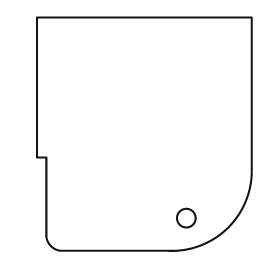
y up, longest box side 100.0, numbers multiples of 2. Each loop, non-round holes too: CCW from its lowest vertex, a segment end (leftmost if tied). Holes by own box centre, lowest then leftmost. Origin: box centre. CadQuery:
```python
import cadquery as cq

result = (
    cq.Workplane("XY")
    .moveTo(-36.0, -50.0)
    .lineTo(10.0, -50.0)
    .threePointArc((36.0, -40.0), (46.0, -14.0))
    .lineTo(46.0, 50.0)
    .lineTo(-46.0, 50.0)
    .lineTo(-46.0, -10.0)
    .lineTo(-42.0, -10.0)
    .lineTo(-42.0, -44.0)
    .threePointArc((-40.0, -48.0), (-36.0, -50.0))
    .close()
    .moveTo(18.0, -36.0)
    .circle(4.0)
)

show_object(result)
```